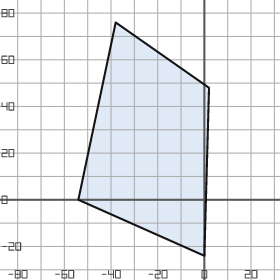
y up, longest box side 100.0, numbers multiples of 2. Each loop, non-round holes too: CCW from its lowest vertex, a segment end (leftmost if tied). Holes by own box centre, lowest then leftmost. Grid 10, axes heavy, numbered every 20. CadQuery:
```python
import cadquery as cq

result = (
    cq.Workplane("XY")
    .moveTo(0.0, -24.0)
    .lineTo(2.0, 48.0)
    .lineTo(-38.0, 76.0)
    .lineTo(-54.0, 0.0)
    .close()
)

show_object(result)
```